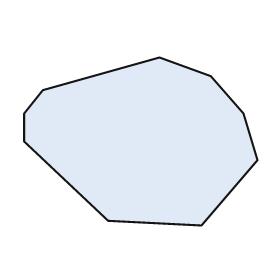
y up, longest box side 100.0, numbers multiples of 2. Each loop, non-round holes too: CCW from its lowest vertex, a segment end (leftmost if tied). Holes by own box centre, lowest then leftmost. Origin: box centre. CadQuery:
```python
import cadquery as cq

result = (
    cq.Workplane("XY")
    .moveTo(26.0, -36.0)
    .lineTo(50.0, -8.0)
    .lineTo(44.0, 12.0)
    .lineTo(30.0, 28.0)
    .lineTo(8.0, 36.0)
    .lineTo(-42.0, 22.0)
    .lineTo(-50.0, 12.0)
    .lineTo(-50.0, 0.0)
    .lineTo(-14.0, -34.0)
    .close()
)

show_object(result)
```